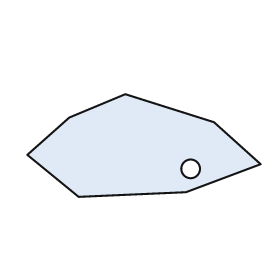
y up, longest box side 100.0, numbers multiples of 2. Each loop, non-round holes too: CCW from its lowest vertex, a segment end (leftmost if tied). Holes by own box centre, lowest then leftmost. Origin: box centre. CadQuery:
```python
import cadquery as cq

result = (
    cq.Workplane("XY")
    .moveTo(-28.0, -22.0)
    .lineTo(18.0, -20.0)
    .lineTo(50.0, -8.0)
    .lineTo(30.0, 10.0)
    .lineTo(-8.0, 22.0)
    .lineTo(-32.0, 12.0)
    .lineTo(-50.0, -4.0)
    .close()
    .moveTo(20.0, -10.0)
    .circle(4.0)
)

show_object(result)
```